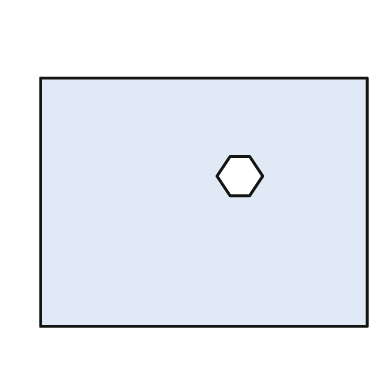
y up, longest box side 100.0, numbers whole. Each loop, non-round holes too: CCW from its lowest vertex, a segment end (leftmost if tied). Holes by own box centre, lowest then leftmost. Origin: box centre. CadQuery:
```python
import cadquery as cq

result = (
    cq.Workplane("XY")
    .moveTo(-50.0, -38.0)
    .lineTo(50.0, -38.0)
    .lineTo(50.0, 38.0)
    .lineTo(-50.0, 38.0)
    .close()
    .moveTo(8.0, 2.0)
    .lineTo(14.0, 2.0)
    .lineTo(18.0, 8.0)
    .lineTo(14.0, 14.0)
    .lineTo(8.0, 14.0)
    .lineTo(4.0, 8.0)
    .close()
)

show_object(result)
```